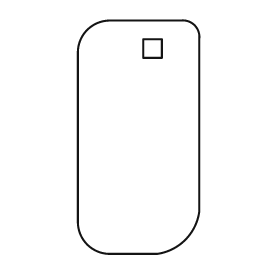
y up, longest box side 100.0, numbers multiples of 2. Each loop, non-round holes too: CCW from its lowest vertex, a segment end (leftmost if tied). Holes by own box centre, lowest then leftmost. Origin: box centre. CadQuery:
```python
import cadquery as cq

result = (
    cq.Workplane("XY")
    .moveTo(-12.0, -50.0)
    .lineTo(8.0, -50.0)
    .threePointArc((20.0, -44.0), (26.0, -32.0))
    .lineTo(26.0, 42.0)
    .threePointArc((24.0, 48.0), (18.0, 50.0))
    .lineTo(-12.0, 50.0)
    .threePointArc((-22.0, 46.0), (-26.0, 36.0))
    .lineTo(-26.0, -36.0)
    .threePointArc((-22.0, -46.0), (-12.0, -50.0))
    .close()
    .moveTo(2.0, 34.0)
    .lineTo(10.0, 34.0)
    .lineTo(10.0, 42.0)
    .lineTo(2.0, 42.0)
    .close()
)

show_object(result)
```